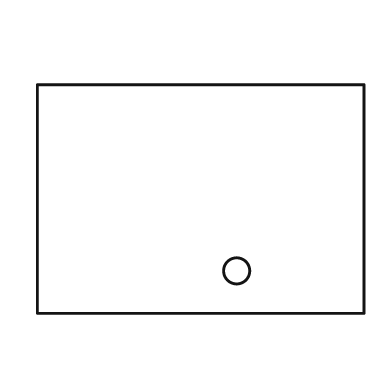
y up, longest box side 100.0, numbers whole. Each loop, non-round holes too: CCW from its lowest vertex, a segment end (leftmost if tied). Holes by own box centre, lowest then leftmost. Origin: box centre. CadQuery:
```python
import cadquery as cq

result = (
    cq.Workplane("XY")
    .moveTo(-50.0, -35.0)
    .lineTo(50.0, -35.0)
    .lineTo(50.0, 35.0)
    .lineTo(-50.0, 35.0)
    .close()
    .moveTo(11.0, -22.0)
    .circle(4.0)
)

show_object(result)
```